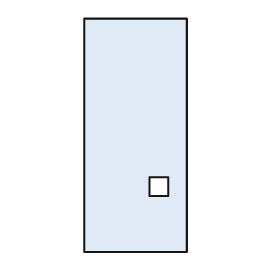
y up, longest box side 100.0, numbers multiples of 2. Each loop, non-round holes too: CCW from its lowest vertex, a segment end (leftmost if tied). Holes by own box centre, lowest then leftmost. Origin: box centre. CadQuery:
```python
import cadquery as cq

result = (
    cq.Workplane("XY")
    .moveTo(-22.0, -50.0)
    .lineTo(22.0, -50.0)
    .lineTo(22.0, 50.0)
    .lineTo(-22.0, 50.0)
    .close()
    .moveTo(6.0, -26.0)
    .lineTo(14.0, -26.0)
    .lineTo(14.0, -18.0)
    .lineTo(6.0, -18.0)
    .close()
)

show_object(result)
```